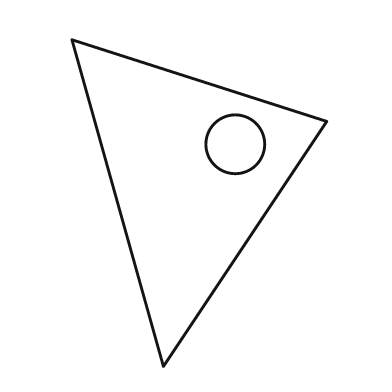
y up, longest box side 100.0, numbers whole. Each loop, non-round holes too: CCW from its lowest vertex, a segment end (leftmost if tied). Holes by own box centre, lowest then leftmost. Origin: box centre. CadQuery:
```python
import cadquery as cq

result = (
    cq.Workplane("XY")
    .moveTo(-11.0, -50.0)
    .lineTo(39.0, 25.0)
    .lineTo(-39.0, 50.0)
    .close()
    .moveTo(11.0, 18.0)
    .circle(9.0)
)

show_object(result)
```